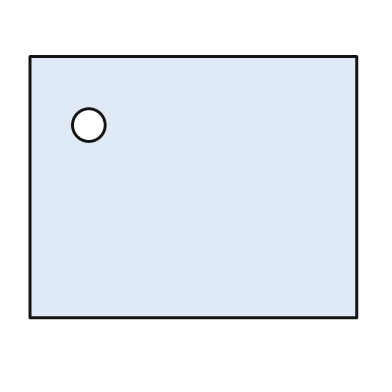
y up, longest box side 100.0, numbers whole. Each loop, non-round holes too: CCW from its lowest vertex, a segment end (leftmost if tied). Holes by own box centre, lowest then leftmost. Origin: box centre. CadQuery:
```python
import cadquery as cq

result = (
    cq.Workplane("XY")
    .moveTo(-50.0, -40.0)
    .lineTo(50.0, -40.0)
    .lineTo(50.0, 40.0)
    .lineTo(-50.0, 40.0)
    .close()
    .moveTo(-32.0, 19.0)
    .circle(5.0)
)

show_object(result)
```